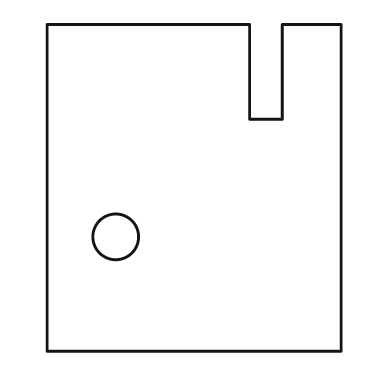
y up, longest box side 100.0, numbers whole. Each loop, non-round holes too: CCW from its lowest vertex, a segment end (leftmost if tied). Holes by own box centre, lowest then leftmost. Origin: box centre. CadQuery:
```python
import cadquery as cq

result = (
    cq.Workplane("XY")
    .moveTo(-45.0, -50.0)
    .lineTo(45.0, -50.0)
    .lineTo(45.0, 50.0)
    .lineTo(27.0, 50.0)
    .lineTo(27.0, 21.0)
    .lineTo(17.0, 21.0)
    .lineTo(17.0, 50.0)
    .lineTo(-45.0, 50.0)
    .close()
    .moveTo(-24.0, -15.0)
    .circle(7.0)
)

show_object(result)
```